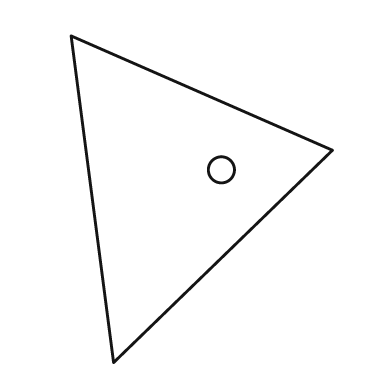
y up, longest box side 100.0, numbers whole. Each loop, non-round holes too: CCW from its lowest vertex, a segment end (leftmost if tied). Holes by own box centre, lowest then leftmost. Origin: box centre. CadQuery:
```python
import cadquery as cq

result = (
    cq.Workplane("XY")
    .moveTo(-27.0, -50.0)
    .lineTo(40.0, 15.0)
    .lineTo(-40.0, 50.0)
    .close()
    .moveTo(6.0, 9.0)
    .circle(4.0)
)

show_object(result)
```